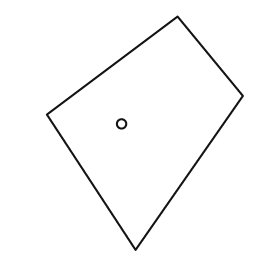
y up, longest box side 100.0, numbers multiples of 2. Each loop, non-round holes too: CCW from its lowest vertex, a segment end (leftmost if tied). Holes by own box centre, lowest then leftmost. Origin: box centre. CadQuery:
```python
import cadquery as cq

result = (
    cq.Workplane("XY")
    .moveTo(-4.0, -50.0)
    .lineTo(42.0, 16.0)
    .lineTo(14.0, 50.0)
    .lineTo(-42.0, 8.0)
    .close()
    .moveTo(-10.0, 4.0)
    .circle(2.0)
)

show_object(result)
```